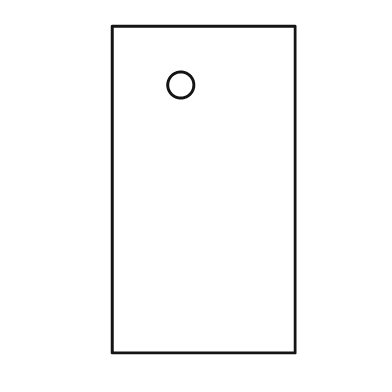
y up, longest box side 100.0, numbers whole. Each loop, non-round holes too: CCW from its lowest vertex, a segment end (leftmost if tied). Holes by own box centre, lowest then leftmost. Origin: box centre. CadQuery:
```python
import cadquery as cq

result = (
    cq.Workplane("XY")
    .moveTo(-28.0, -50.0)
    .lineTo(28.0, -50.0)
    .lineTo(28.0, 50.0)
    .lineTo(-28.0, 50.0)
    .close()
    .moveTo(-7.0, 32.0)
    .circle(4.0)
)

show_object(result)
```